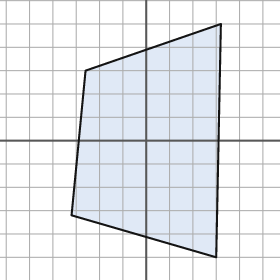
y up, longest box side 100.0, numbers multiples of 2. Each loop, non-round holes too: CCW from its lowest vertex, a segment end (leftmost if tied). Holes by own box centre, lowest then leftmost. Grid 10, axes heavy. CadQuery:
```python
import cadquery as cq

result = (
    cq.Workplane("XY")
    .moveTo(30.0, -50.0)
    .lineTo(32.0, 50.0)
    .lineTo(-26.0, 30.0)
    .lineTo(-32.0, -32.0)
    .close()
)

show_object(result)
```